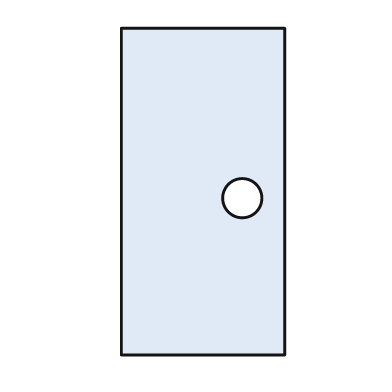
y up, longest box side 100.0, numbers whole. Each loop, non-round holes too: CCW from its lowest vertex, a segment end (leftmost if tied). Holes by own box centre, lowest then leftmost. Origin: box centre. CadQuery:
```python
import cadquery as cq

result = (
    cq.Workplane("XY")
    .moveTo(-25.0, -50.0)
    .lineTo(25.0, -50.0)
    .lineTo(25.0, 50.0)
    .lineTo(-25.0, 50.0)
    .close()
    .moveTo(12.0, -2.0)
    .circle(6.0)
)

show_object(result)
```